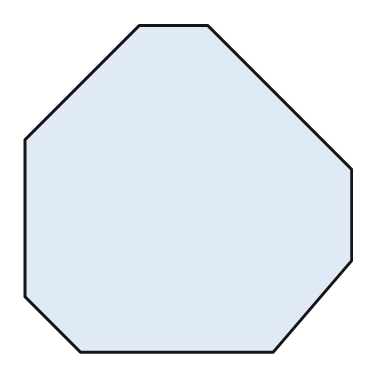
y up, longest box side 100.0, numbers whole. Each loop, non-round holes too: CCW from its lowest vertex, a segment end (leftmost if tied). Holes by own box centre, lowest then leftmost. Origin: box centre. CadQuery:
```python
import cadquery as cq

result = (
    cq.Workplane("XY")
    .moveTo(-33.0, -50.0)
    .lineTo(26.0, -50.0)
    .lineTo(50.0, -22.0)
    .lineTo(50.0, 6.0)
    .lineTo(6.0, 50.0)
    .lineTo(-15.0, 50.0)
    .lineTo(-50.0, 15.0)
    .lineTo(-50.0, -33.0)
    .close()
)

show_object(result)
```